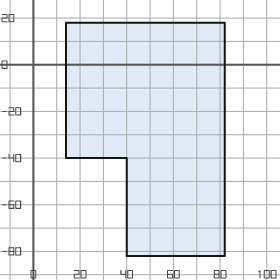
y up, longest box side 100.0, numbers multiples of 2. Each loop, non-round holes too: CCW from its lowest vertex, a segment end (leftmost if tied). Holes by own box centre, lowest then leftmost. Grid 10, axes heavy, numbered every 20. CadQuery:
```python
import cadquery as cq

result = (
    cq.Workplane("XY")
    .moveTo(40.0, -82.0)
    .lineTo(82.0, -82.0)
    .lineTo(82.0, 18.0)
    .lineTo(14.0, 18.0)
    .lineTo(14.0, -40.0)
    .lineTo(40.0, -40.0)
    .close()
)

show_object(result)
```